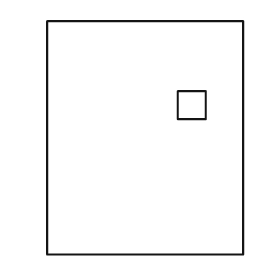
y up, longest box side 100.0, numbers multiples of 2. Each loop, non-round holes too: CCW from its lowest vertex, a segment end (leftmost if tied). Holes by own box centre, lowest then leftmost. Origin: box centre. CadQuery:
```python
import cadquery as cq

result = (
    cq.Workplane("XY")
    .moveTo(-42.0, -50.0)
    .lineTo(42.0, -50.0)
    .lineTo(42.0, 50.0)
    .lineTo(-42.0, 50.0)
    .close()
    .moveTo(14.0, 8.0)
    .lineTo(26.0, 8.0)
    .lineTo(26.0, 20.0)
    .lineTo(14.0, 20.0)
    .close()
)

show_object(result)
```